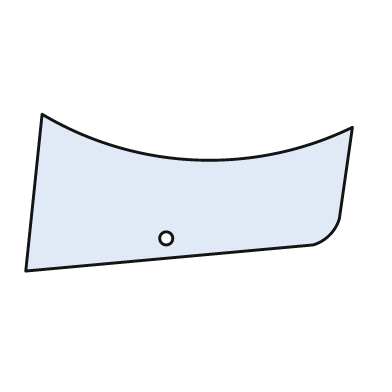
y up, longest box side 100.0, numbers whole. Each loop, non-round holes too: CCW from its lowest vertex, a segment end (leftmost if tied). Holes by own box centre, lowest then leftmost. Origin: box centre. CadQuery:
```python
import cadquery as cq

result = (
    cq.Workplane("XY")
    .moveTo(-50.0, -24.0)
    .lineTo(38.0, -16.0)
    .threePointArc((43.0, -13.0), (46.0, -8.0))
    .lineTo(50.0, 20.0)
    .threePointArc((2.0, 10.0), (-45.0, 24.0))
    .close()
    .moveTo(-7.0, -14.0)
    .circle(2.0)
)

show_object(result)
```